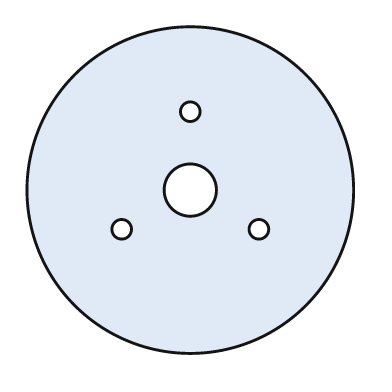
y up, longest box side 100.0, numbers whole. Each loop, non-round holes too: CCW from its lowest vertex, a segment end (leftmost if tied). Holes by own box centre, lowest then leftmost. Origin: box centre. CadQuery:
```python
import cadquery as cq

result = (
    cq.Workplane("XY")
    .moveTo(0.0, 0.0)
    .circle(50.0)
    .moveTo(-21.0, -12.0)
    .circle(3.0)
    .moveTo(21.0, -12.0)
    .circle(3.0)
    .moveTo(0.0, 0.0)
    .circle(8.0)
    .moveTo(0.0, 24.0)
    .circle(3.0)
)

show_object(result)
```